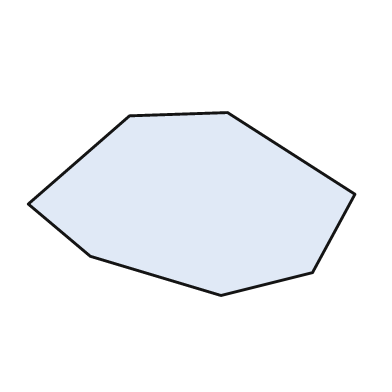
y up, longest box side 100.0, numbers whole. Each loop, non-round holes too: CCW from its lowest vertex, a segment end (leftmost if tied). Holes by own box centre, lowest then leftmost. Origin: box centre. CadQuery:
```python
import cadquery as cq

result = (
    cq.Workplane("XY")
    .moveTo(9.0, -28.0)
    .lineTo(37.0, -21.0)
    .lineTo(50.0, 3.0)
    .lineTo(11.0, 28.0)
    .lineTo(-19.0, 27.0)
    .lineTo(-50.0, 0.0)
    .lineTo(-31.0, -16.0)
    .close()
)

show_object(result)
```